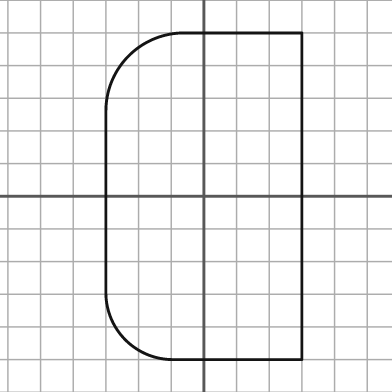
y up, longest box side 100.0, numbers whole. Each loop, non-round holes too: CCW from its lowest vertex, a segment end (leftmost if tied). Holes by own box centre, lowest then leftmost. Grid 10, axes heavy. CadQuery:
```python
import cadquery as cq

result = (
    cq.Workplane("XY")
    .moveTo(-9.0, -50.0)
    .lineTo(30.0, -50.0)
    .lineTo(30.0, 50.0)
    .lineTo(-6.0, 50.0)
    .threePointArc((-23.0, 43.0), (-30.0, 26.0))
    .lineTo(-30.0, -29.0)
    .threePointArc((-24.0, -44.0), (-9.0, -50.0))
    .close()
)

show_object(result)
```